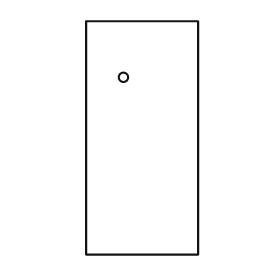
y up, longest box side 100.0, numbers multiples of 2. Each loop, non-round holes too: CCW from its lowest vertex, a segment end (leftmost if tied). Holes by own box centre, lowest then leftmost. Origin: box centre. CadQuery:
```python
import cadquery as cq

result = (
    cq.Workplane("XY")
    .moveTo(-24.0, -50.0)
    .lineTo(24.0, -50.0)
    .lineTo(24.0, 50.0)
    .lineTo(-24.0, 50.0)
    .close()
    .moveTo(-8.0, 26.0)
    .circle(2.0)
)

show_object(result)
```